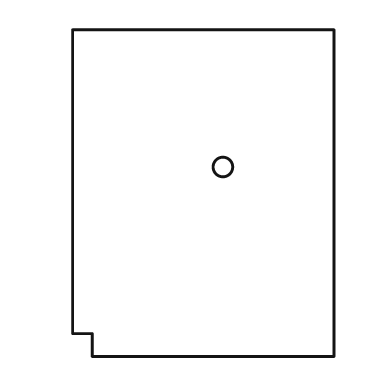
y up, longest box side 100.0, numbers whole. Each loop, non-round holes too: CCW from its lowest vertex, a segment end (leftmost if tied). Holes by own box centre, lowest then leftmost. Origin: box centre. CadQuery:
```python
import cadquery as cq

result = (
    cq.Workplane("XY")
    .moveTo(-34.0, -50.0)
    .lineTo(40.0, -50.0)
    .lineTo(40.0, 50.0)
    .lineTo(-40.0, 50.0)
    .lineTo(-40.0, -43.0)
    .lineTo(-34.0, -43.0)
    .close()
    .moveTo(6.0, 8.0)
    .circle(3.0)
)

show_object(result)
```